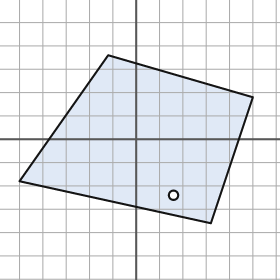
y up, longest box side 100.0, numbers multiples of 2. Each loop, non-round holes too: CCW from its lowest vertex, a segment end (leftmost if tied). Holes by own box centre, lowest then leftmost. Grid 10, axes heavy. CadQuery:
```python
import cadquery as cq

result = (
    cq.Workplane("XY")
    .moveTo(32.0, -36.0)
    .lineTo(50.0, 18.0)
    .lineTo(-12.0, 36.0)
    .lineTo(-50.0, -18.0)
    .close()
    .moveTo(16.0, -24.0)
    .circle(2.0)
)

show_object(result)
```